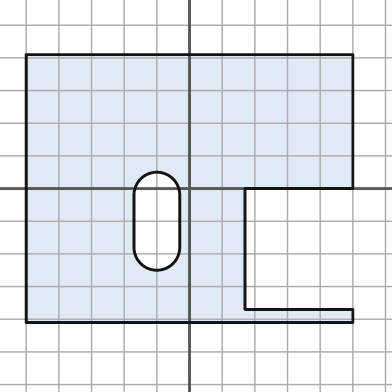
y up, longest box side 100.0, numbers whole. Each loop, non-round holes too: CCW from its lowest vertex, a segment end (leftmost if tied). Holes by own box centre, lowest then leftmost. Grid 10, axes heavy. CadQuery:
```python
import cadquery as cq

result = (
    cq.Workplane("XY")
    .moveTo(-50.0, -41.0)
    .lineTo(50.0, -41.0)
    .lineTo(50.0, -37.0)
    .lineTo(17.0, -37.0)
    .lineTo(17.0, 0.0)
    .lineTo(50.0, 0.0)
    .lineTo(50.0, 41.0)
    .lineTo(-50.0, 41.0)
    .close()
    .moveTo(-17.0, -18.0)
    .threePointArc((-10.0, -25.0), (-3.0, -18.0))
    .lineTo(-3.0, -2.0)
    .threePointArc((-10.0, 5.0), (-17.0, -2.0))
    .close()
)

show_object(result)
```